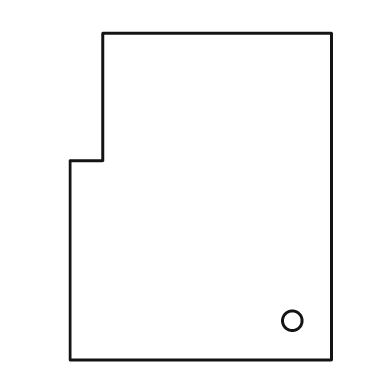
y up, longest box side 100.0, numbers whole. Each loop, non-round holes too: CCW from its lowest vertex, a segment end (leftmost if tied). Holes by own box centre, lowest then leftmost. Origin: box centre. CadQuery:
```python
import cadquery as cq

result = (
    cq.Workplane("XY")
    .moveTo(-40.0, -50.0)
    .lineTo(40.0, -50.0)
    .lineTo(40.0, 50.0)
    .lineTo(-30.0, 50.0)
    .lineTo(-30.0, 11.0)
    .lineTo(-40.0, 11.0)
    .close()
    .moveTo(28.0, -38.0)
    .circle(3.0)
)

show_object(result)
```